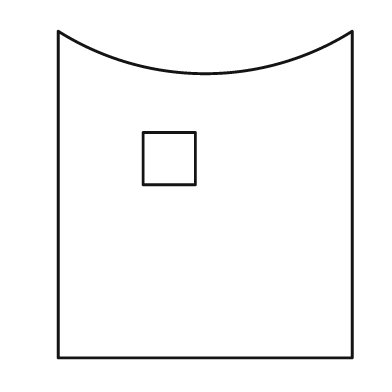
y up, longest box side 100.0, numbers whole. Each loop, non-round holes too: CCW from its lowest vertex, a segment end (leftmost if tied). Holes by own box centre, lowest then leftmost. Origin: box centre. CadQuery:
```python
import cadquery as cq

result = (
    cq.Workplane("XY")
    .moveTo(-45.0, -50.0)
    .lineTo(45.0, -50.0)
    .lineTo(45.0, 50.0)
    .threePointArc((0.0, 37.0), (-45.0, 50.0))
    .close()
    .moveTo(-19.0, 3.0)
    .lineTo(-3.0, 3.0)
    .lineTo(-3.0, 19.0)
    .lineTo(-19.0, 19.0)
    .close()
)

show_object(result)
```